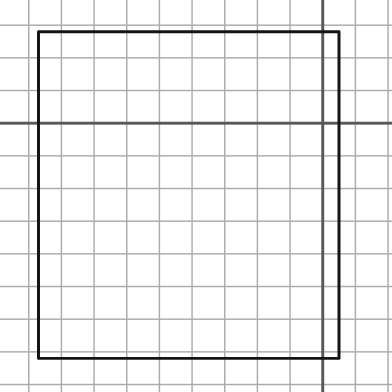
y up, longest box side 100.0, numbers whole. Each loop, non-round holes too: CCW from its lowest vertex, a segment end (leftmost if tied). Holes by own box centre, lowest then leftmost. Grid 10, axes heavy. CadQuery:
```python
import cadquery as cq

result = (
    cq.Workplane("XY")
    .moveTo(-87.0, -72.0)
    .lineTo(5.0, -72.0)
    .lineTo(5.0, 28.0)
    .lineTo(-87.0, 28.0)
    .close()
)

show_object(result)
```